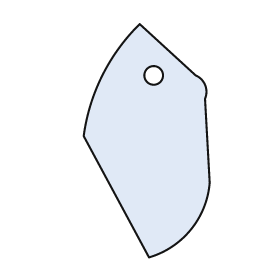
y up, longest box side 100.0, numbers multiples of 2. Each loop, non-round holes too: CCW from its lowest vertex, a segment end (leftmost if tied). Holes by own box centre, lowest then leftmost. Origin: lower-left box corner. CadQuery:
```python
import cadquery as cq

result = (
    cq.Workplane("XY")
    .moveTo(28.0, 0.0)
    .threePointArc((46.0, 12.0), (54.0, 32.0))
    .lineTo(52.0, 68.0)
    .threePointArc((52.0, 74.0), (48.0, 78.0))
    .lineTo(24.0, 100.0)
    .threePointArc((8.0, 78.0), (0.0, 52.0))
    .close()
    .moveTo(30.0, 78.0)
    .circle(4.0)
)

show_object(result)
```